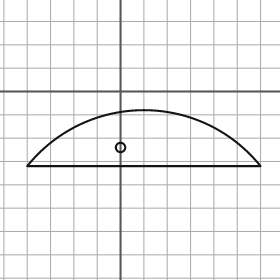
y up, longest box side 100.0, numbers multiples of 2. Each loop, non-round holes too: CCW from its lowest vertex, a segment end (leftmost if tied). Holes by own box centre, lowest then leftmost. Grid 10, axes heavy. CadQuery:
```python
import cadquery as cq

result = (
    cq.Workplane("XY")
    .moveTo(-40.0, -32.0)
    .lineTo(60.0, -32.0)
    .threePointArc((10.0, -8.0), (-40.0, -32.0))
    .close()
    .moveTo(0.0, -24.0)
    .circle(2.0)
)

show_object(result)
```